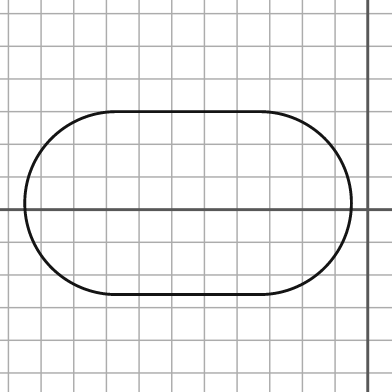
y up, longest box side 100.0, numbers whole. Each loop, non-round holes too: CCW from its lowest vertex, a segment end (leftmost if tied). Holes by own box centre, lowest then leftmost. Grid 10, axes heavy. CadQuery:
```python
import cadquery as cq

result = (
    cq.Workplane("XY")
    .moveTo(-77.0, -26.0)
    .lineTo(-33.0, -26.0)
    .threePointArc((-5.0, 2.0), (-33.0, 30.0))
    .lineTo(-77.0, 30.0)
    .threePointArc((-105.0, 2.0), (-77.0, -26.0))
    .close()
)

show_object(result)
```